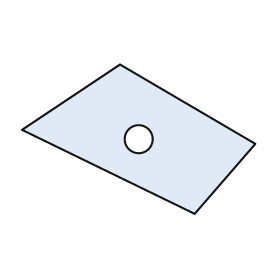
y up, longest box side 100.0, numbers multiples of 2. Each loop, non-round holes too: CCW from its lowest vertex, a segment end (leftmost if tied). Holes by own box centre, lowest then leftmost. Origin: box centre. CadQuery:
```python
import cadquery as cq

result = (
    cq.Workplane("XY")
    .moveTo(24.0, -32.0)
    .lineTo(50.0, -2.0)
    .lineTo(-8.0, 32.0)
    .lineTo(-50.0, 4.0)
    .close()
    .moveTo(0.0, 0.0)
    .circle(6.0)
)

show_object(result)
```